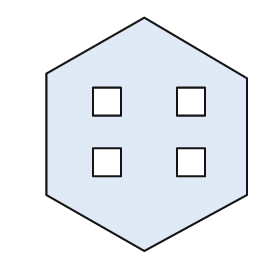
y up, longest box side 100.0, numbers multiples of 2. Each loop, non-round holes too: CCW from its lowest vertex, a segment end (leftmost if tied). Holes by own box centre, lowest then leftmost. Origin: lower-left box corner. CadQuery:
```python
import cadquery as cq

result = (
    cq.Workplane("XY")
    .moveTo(42.0, 0.0)
    .lineTo(86.0, 24.0)
    .lineTo(86.0, 74.0)
    .lineTo(42.0, 100.0)
    .lineTo(0.0, 76.0)
    .lineTo(0.0, 24.0)
    .close()
    .moveTo(20.0, 32.0)
    .lineTo(32.0, 32.0)
    .lineTo(32.0, 44.0)
    .lineTo(20.0, 44.0)
    .close()
    .moveTo(56.0, 32.0)
    .lineTo(68.0, 32.0)
    .lineTo(68.0, 44.0)
    .lineTo(56.0, 44.0)
    .close()
    .moveTo(20.0, 58.0)
    .lineTo(32.0, 58.0)
    .lineTo(32.0, 70.0)
    .lineTo(20.0, 70.0)
    .close()
    .moveTo(56.0, 58.0)
    .lineTo(68.0, 58.0)
    .lineTo(68.0, 70.0)
    .lineTo(56.0, 70.0)
    .close()
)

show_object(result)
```